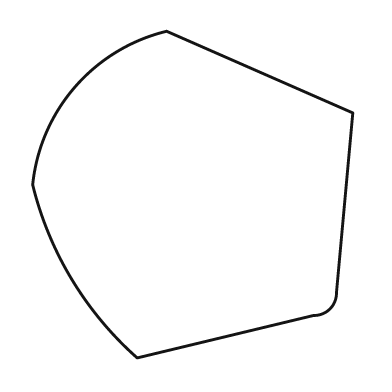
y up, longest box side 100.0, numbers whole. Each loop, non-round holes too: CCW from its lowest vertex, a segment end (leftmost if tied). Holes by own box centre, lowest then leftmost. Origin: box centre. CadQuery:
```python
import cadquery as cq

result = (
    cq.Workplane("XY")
    .moveTo(-17.0, -50.0)
    .lineTo(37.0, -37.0)
    .threePointArc((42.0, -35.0), (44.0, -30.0))
    .lineTo(49.0, 25.0)
    .lineTo(-8.0, 50.0)
    .threePointArc((-36.0, 33.0), (-49.0, 3.0))
    .threePointArc((-37.0, -26.0), (-17.0, -50.0))
    .close()
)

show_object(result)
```